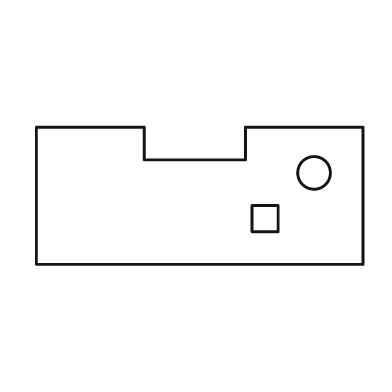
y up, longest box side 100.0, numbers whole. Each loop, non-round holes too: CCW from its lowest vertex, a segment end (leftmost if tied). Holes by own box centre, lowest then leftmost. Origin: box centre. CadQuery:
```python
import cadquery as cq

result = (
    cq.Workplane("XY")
    .moveTo(-50.0, -21.0)
    .lineTo(50.0, -21.0)
    .lineTo(50.0, 21.0)
    .lineTo(14.0, 21.0)
    .lineTo(14.0, 11.0)
    .lineTo(-17.0, 11.0)
    .lineTo(-17.0, 21.0)
    .lineTo(-50.0, 21.0)
    .close()
    .moveTo(16.0, -11.0)
    .lineTo(24.0, -11.0)
    .lineTo(24.0, -3.0)
    .lineTo(16.0, -3.0)
    .close()
    .moveTo(35.0, 7.0)
    .circle(5.0)
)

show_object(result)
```